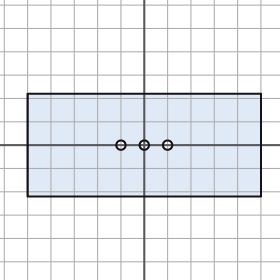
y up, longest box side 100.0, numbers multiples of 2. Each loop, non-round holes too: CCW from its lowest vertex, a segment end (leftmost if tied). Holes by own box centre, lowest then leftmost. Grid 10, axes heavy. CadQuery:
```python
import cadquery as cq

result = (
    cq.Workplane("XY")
    .moveTo(-50.0, -22.0)
    .lineTo(50.0, -22.0)
    .lineTo(50.0, 22.0)
    .lineTo(-50.0, 22.0)
    .close()
    .moveTo(-10.0, 0.0)
    .circle(2.0)
    .moveTo(0.0, 0.0)
    .circle(2.0)
    .moveTo(10.0, 0.0)
    .circle(2.0)
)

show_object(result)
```